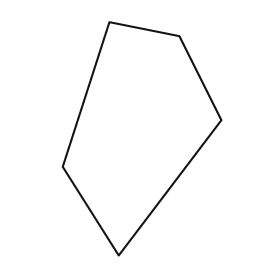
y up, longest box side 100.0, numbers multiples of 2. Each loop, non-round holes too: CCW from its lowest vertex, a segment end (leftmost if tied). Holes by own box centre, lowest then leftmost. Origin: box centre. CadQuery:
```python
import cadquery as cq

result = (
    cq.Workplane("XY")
    .moveTo(-10.0, -50.0)
    .lineTo(34.0, 8.0)
    .lineTo(16.0, 44.0)
    .lineTo(-14.0, 50.0)
    .lineTo(-34.0, -12.0)
    .close()
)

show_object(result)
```